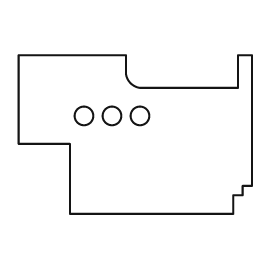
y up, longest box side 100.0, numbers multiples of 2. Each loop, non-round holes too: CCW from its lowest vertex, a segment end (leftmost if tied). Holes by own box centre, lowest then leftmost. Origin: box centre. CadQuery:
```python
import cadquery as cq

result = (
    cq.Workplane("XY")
    .moveTo(-28.0, -34.0)
    .lineTo(42.0, -34.0)
    .lineTo(42.0, -26.0)
    .lineTo(46.0, -26.0)
    .lineTo(46.0, -22.0)
    .lineTo(50.0, -22.0)
    .lineTo(50.0, 34.0)
    .lineTo(44.0, 34.0)
    .lineTo(44.0, 20.0)
    .lineTo(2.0, 20.0)
    .threePointArc((-2.0, 22.0), (-4.0, 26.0))
    .lineTo(-4.0, 34.0)
    .lineTo(-50.0, 34.0)
    .lineTo(-50.0, -4.0)
    .lineTo(-28.0, -4.0)
    .close()
    .moveTo(-22.0, 8.0)
    .circle(4.0)
    .moveTo(-10.0, 8.0)
    .circle(4.0)
    .moveTo(2.0, 8.0)
    .circle(4.0)
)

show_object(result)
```